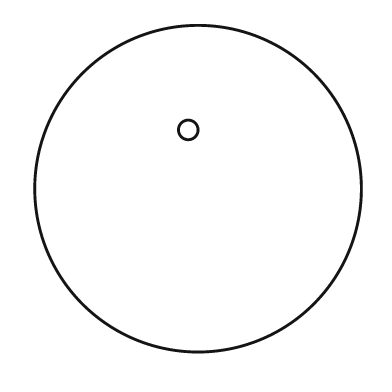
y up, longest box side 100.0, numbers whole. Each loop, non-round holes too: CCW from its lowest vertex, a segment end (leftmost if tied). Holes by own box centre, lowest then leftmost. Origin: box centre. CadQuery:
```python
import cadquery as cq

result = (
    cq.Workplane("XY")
    .moveTo(0.0, 0.0)
    .circle(50.0)
    .moveTo(-3.0, 18.0)
    .circle(3.0)
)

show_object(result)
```